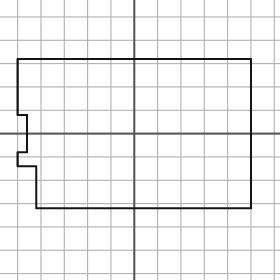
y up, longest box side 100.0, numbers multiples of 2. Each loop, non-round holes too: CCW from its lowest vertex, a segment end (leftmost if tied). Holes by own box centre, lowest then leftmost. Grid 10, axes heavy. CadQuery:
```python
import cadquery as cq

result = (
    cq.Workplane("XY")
    .moveTo(-42.0, -32.0)
    .lineTo(50.0, -32.0)
    .lineTo(50.0, 32.0)
    .lineTo(-50.0, 32.0)
    .lineTo(-50.0, 8.0)
    .lineTo(-46.0, 8.0)
    .lineTo(-46.0, -8.0)
    .lineTo(-50.0, -8.0)
    .lineTo(-50.0, -14.0)
    .lineTo(-42.0, -14.0)
    .close()
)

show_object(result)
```